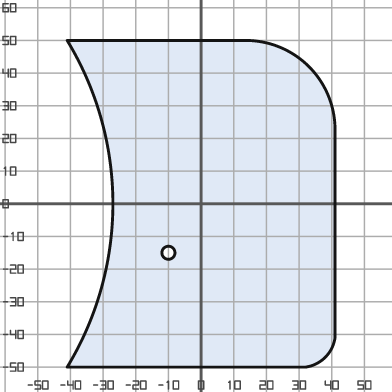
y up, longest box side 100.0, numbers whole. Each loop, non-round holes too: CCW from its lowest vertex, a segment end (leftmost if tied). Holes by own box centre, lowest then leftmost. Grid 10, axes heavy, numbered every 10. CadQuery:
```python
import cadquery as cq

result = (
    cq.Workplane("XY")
    .moveTo(-41.0, -50.0)
    .lineTo(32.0, -50.0)
    .threePointArc((38.0, -47.0), (41.0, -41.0))
    .lineTo(41.0, 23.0)
    .threePointArc((33.0, 42.0), (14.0, 50.0))
    .lineTo(-41.0, 50.0)
    .threePointArc((-27.0, 0.0), (-41.0, -50.0))
    .close()
    .moveTo(-10.0, -15.0)
    .circle(2.0)
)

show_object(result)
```